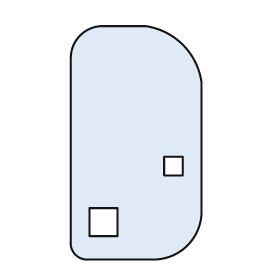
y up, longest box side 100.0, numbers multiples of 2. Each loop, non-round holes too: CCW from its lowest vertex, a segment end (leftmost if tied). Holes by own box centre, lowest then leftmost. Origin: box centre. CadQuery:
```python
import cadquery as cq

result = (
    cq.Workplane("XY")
    .moveTo(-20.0, -50.0)
    .lineTo(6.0, -50.0)
    .threePointArc((22.0, -44.0), (28.0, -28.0))
    .lineTo(28.0, 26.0)
    .threePointArc((20.0, 42.0), (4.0, 50.0))
    .lineTo(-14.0, 50.0)
    .threePointArc((-24.0, 46.0), (-28.0, 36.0))
    .lineTo(-28.0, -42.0)
    .threePointArc((-26.0, -48.0), (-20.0, -50.0))
    .close()
    .moveTo(-20.0, -40.0)
    .lineTo(-8.0, -40.0)
    .lineTo(-8.0, -28.0)
    .lineTo(-20.0, -28.0)
    .close()
    .moveTo(12.0, -14.0)
    .lineTo(20.0, -14.0)
    .lineTo(20.0, -6.0)
    .lineTo(12.0, -6.0)
    .close()
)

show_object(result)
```